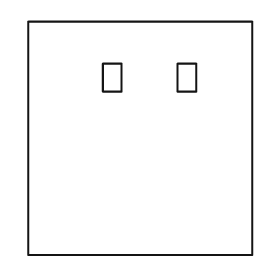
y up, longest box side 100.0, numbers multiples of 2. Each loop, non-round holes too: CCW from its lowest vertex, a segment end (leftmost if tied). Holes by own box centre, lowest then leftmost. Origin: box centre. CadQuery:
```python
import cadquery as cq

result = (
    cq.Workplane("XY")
    .moveTo(-48.0, -50.0)
    .lineTo(48.0, -50.0)
    .lineTo(48.0, 50.0)
    .lineTo(-48.0, 50.0)
    .close()
    .moveTo(-16.0, 20.0)
    .lineTo(-8.0, 20.0)
    .lineTo(-8.0, 32.0)
    .lineTo(-16.0, 32.0)
    .close()
    .moveTo(16.0, 20.0)
    .lineTo(24.0, 20.0)
    .lineTo(24.0, 32.0)
    .lineTo(16.0, 32.0)
    .close()
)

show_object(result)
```